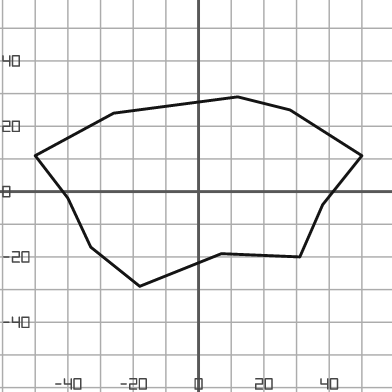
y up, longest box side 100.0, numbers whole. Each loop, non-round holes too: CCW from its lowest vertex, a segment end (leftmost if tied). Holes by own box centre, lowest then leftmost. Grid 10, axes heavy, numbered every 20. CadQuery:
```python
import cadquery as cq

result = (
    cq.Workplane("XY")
    .moveTo(-18.0, -29.0)
    .lineTo(7.0, -19.0)
    .lineTo(31.0, -20.0)
    .lineTo(38.0, -4.0)
    .lineTo(50.0, 11.0)
    .lineTo(28.0, 25.0)
    .lineTo(12.0, 29.0)
    .lineTo(-26.0, 24.0)
    .lineTo(-50.0, 11.0)
    .lineTo(-40.0, -2.0)
    .lineTo(-33.0, -17.0)
    .close()
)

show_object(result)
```